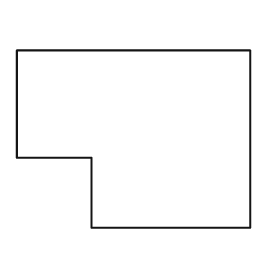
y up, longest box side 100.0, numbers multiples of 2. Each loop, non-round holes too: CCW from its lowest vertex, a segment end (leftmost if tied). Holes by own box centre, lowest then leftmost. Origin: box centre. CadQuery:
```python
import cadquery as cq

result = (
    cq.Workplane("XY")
    .moveTo(-18.0, -38.0)
    .lineTo(50.0, -38.0)
    .lineTo(50.0, 38.0)
    .lineTo(-50.0, 38.0)
    .lineTo(-50.0, -8.0)
    .lineTo(-18.0, -8.0)
    .close()
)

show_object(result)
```